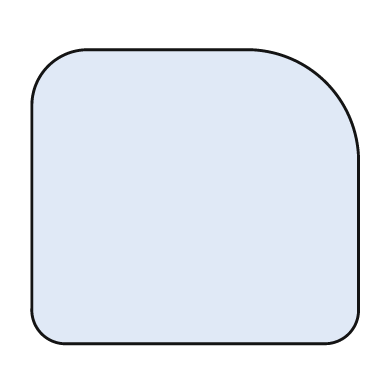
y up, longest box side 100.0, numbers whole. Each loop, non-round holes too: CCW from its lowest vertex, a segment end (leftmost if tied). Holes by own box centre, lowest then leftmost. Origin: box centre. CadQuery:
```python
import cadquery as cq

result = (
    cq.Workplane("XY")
    .moveTo(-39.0, -45.0)
    .lineTo(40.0, -45.0)
    .threePointArc((47.0, -42.0), (50.0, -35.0))
    .lineTo(50.0, 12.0)
    .threePointArc((40.0, 35.0), (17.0, 45.0))
    .lineTo(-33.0, 45.0)
    .threePointArc((-45.0, 40.0), (-50.0, 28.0))
    .lineTo(-50.0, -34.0)
    .threePointArc((-47.0, -42.0), (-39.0, -45.0))
    .close()
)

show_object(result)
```